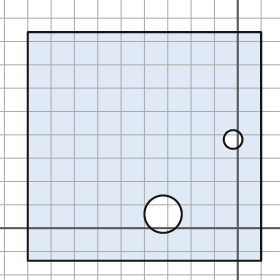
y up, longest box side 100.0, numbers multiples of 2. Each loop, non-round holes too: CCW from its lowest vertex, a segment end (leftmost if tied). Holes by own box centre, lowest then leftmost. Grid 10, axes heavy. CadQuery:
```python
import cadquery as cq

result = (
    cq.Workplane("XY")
    .moveTo(-90.0, -14.0)
    .lineTo(10.0, -14.0)
    .lineTo(10.0, 84.0)
    .lineTo(-90.0, 84.0)
    .close()
    .moveTo(-32.0, 6.0)
    .circle(8.0)
    .moveTo(-2.0, 38.0)
    .circle(4.0)
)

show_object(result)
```